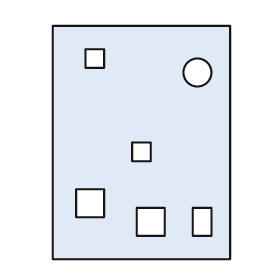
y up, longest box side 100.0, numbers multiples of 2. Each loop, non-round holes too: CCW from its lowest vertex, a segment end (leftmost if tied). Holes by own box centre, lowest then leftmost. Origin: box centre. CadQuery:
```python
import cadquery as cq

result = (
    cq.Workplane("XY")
    .moveTo(-38.0, -50.0)
    .lineTo(38.0, -50.0)
    .lineTo(38.0, 50.0)
    .lineTo(-38.0, 50.0)
    .close()
    .moveTo(-2.0, -40.0)
    .lineTo(10.0, -40.0)
    .lineTo(10.0, -28.0)
    .lineTo(-2.0, -28.0)
    .close()
    .moveTo(22.0, -40.0)
    .lineTo(30.0, -40.0)
    .lineTo(30.0, -28.0)
    .lineTo(22.0, -28.0)
    .close()
    .moveTo(-28.0, -32.0)
    .lineTo(-16.0, -32.0)
    .lineTo(-16.0, -20.0)
    .lineTo(-28.0, -20.0)
    .close()
    .moveTo(-4.0, -8.0)
    .lineTo(4.0, -8.0)
    .lineTo(4.0, 0.0)
    .lineTo(-4.0, 0.0)
    .close()
    .moveTo(24.0, 30.0)
    .circle(6.0)
    .moveTo(-24.0, 32.0)
    .lineTo(-16.0, 32.0)
    .lineTo(-16.0, 40.0)
    .lineTo(-24.0, 40.0)
    .close()
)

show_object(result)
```